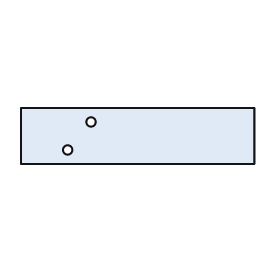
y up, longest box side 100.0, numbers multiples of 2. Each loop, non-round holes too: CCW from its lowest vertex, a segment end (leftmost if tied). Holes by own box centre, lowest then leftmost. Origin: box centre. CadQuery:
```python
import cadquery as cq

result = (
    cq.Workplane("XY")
    .moveTo(-50.0, -12.0)
    .lineTo(50.0, -12.0)
    .lineTo(50.0, 12.0)
    .lineTo(-50.0, 12.0)
    .close()
    .moveTo(-30.0, -6.0)
    .circle(2.0)
    .moveTo(-20.0, 6.0)
    .circle(2.0)
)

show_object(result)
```